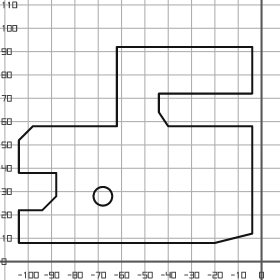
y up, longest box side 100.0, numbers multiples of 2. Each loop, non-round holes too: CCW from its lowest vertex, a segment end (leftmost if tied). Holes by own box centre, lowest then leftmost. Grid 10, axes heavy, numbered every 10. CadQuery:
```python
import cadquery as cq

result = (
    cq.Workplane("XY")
    .moveTo(-104.0, 8.0)
    .lineTo(-20.0, 8.0)
    .lineTo(-4.0, 12.0)
    .lineTo(-4.0, 58.0)
    .lineTo(-40.0, 58.0)
    .lineTo(-44.0, 64.0)
    .lineTo(-44.0, 72.0)
    .lineTo(-4.0, 72.0)
    .lineTo(-4.0, 92.0)
    .lineTo(-62.0, 92.0)
    .lineTo(-62.0, 58.0)
    .lineTo(-98.0, 58.0)
    .lineTo(-104.0, 52.0)
    .lineTo(-104.0, 38.0)
    .lineTo(-88.0, 38.0)
    .lineTo(-88.0, 28.0)
    .lineTo(-94.0, 22.0)
    .lineTo(-104.0, 22.0)
    .close()
    .moveTo(-68.0, 28.0)
    .circle(4.0)
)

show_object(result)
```